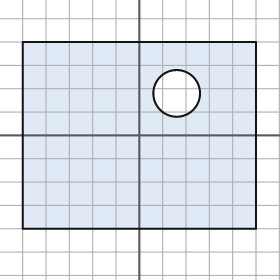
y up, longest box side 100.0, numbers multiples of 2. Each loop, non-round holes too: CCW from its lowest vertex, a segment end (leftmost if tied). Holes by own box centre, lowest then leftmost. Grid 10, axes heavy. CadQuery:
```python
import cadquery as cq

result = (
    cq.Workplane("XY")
    .moveTo(-50.0, -40.0)
    .lineTo(50.0, -40.0)
    .lineTo(50.0, 40.0)
    .lineTo(-50.0, 40.0)
    .close()
    .moveTo(16.0, 18.0)
    .circle(10.0)
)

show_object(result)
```